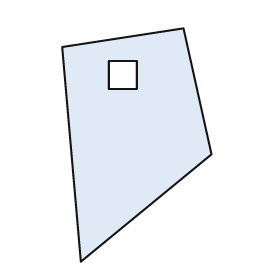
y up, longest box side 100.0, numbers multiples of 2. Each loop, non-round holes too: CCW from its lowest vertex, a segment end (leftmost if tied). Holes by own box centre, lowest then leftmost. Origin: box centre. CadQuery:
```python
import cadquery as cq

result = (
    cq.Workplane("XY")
    .moveTo(-24.0, -50.0)
    .lineTo(32.0, -4.0)
    .lineTo(20.0, 50.0)
    .lineTo(-32.0, 42.0)
    .close()
    .moveTo(-12.0, 24.0)
    .lineTo(0.0, 24.0)
    .lineTo(0.0, 36.0)
    .lineTo(-12.0, 36.0)
    .close()
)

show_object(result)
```